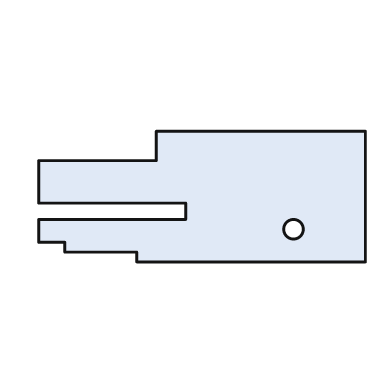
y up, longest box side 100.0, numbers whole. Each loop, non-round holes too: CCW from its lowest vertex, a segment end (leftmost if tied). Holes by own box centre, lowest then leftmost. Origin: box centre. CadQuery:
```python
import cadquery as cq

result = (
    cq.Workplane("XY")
    .moveTo(-20.0, -20.0)
    .lineTo(50.0, -20.0)
    .lineTo(50.0, 20.0)
    .lineTo(-14.0, 20.0)
    .lineTo(-14.0, 11.0)
    .lineTo(-50.0, 11.0)
    .lineTo(-50.0, -2.0)
    .lineTo(-5.0, -2.0)
    .lineTo(-5.0, -7.0)
    .lineTo(-50.0, -7.0)
    .lineTo(-50.0, -14.0)
    .lineTo(-42.0, -14.0)
    .lineTo(-42.0, -17.0)
    .lineTo(-20.0, -17.0)
    .close()
    .moveTo(28.0, -10.0)
    .circle(3.0)
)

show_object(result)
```